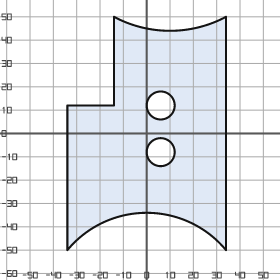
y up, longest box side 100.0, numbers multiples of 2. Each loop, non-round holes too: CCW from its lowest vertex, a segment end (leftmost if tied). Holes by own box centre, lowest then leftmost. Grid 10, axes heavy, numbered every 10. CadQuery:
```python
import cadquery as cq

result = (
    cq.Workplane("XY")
    .moveTo(-34.0, -50.0)
    .threePointArc((0.0, -34.0), (34.0, -50.0))
    .lineTo(34.0, 50.0)
    .threePointArc((10.0, 44.0), (-14.0, 50.0))
    .lineTo(-14.0, 12.0)
    .lineTo(-34.0, 12.0)
    .close()
    .moveTo(6.0, -8.0)
    .circle(6.0)
    .moveTo(6.0, 12.0)
    .circle(6.0)
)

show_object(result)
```